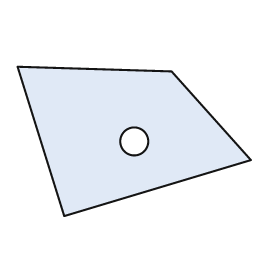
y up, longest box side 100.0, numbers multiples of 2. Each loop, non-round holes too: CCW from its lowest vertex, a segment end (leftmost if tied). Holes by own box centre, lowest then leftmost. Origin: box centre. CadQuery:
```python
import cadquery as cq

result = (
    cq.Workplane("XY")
    .moveTo(-30.0, -32.0)
    .lineTo(50.0, -8.0)
    .lineTo(16.0, 30.0)
    .lineTo(-50.0, 32.0)
    .close()
    .moveTo(0.0, 0.0)
    .circle(6.0)
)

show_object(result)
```